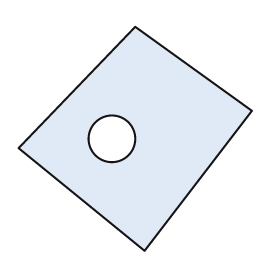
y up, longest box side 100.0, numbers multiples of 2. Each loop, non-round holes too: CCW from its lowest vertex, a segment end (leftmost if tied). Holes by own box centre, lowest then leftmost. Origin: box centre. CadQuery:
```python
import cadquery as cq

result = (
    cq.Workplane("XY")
    .moveTo(4.0, -48.0)
    .lineTo(50.0, 12.0)
    .lineTo(0.0, 48.0)
    .lineTo(-50.0, -4.0)
    .close()
    .moveTo(-10.0, 0.0)
    .circle(10.0)
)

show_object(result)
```